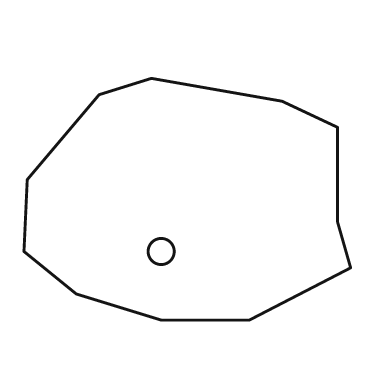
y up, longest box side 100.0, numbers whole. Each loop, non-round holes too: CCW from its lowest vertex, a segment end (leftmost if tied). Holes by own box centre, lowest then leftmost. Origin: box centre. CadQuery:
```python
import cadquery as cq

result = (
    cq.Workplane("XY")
    .moveTo(-8.0, -37.0)
    .lineTo(19.0, -37.0)
    .lineTo(50.0, -21.0)
    .lineTo(46.0, -7.0)
    .lineTo(46.0, 22.0)
    .lineTo(29.0, 30.0)
    .lineTo(-11.0, 37.0)
    .lineTo(-27.0, 32.0)
    .lineTo(-49.0, 6.0)
    .lineTo(-50.0, -16.0)
    .lineTo(-34.0, -29.0)
    .close()
    .moveTo(-8.0, -16.0)
    .circle(4.0)
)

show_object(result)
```